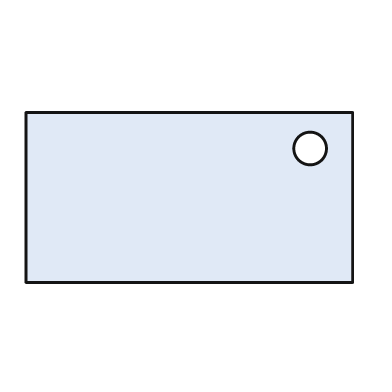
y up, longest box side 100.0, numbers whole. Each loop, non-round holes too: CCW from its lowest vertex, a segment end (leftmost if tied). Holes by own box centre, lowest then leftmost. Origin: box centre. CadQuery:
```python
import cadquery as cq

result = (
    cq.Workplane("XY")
    .moveTo(-50.0, -26.0)
    .lineTo(50.0, -26.0)
    .lineTo(50.0, 26.0)
    .lineTo(-50.0, 26.0)
    .close()
    .moveTo(37.0, 15.0)
    .circle(5.0)
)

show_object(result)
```